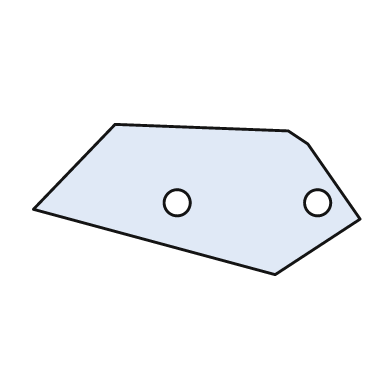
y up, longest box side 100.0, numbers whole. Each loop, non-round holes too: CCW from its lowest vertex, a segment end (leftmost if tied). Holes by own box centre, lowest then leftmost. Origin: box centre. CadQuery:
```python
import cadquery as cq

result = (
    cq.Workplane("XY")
    .moveTo(24.0, -23.0)
    .lineTo(50.0, -6.0)
    .lineTo(34.0, 17.0)
    .lineTo(28.0, 21.0)
    .lineTo(-25.0, 23.0)
    .lineTo(-50.0, -3.0)
    .close()
    .moveTo(-6.0, -1.0)
    .circle(4.0)
    .moveTo(37.0, -1.0)
    .circle(4.0)
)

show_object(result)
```